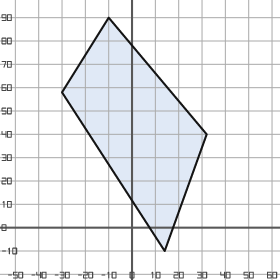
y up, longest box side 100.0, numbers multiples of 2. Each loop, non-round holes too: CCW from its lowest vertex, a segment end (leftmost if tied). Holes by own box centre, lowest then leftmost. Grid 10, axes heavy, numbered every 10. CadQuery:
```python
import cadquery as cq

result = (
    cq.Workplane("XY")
    .moveTo(14.0, -10.0)
    .lineTo(32.0, 40.0)
    .lineTo(-10.0, 90.0)
    .lineTo(-30.0, 58.0)
    .close()
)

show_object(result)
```